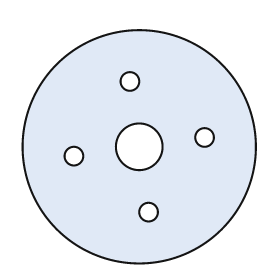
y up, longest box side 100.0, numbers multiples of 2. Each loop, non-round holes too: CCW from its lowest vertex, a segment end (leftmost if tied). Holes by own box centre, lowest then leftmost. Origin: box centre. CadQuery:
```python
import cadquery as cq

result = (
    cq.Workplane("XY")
    .moveTo(0.0, 0.0)
    .circle(50.0)
    .moveTo(4.0, -28.0)
    .circle(4.0)
    .moveTo(-28.0, -4.0)
    .circle(4.0)
    .moveTo(0.0, 0.0)
    .circle(10.0)
    .moveTo(28.0, 4.0)
    .circle(4.0)
    .moveTo(-4.0, 28.0)
    .circle(4.0)
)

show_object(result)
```